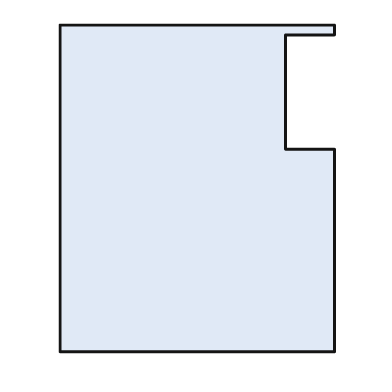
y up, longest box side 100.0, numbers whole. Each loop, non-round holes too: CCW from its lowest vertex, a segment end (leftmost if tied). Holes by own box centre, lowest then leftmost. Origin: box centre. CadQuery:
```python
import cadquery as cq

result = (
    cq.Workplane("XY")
    .moveTo(-42.0, -50.0)
    .lineTo(42.0, -50.0)
    .lineTo(42.0, 12.0)
    .lineTo(27.0, 12.0)
    .lineTo(27.0, 47.0)
    .lineTo(42.0, 47.0)
    .lineTo(42.0, 50.0)
    .lineTo(-42.0, 50.0)
    .close()
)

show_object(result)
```